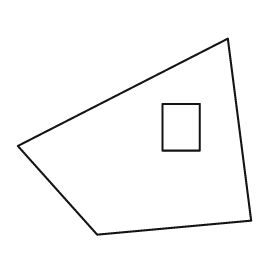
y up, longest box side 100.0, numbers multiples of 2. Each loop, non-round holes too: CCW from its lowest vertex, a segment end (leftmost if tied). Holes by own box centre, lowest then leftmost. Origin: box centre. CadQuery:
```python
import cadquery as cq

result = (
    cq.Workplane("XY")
    .moveTo(-16.0, -42.0)
    .lineTo(50.0, -36.0)
    .lineTo(40.0, 42.0)
    .lineTo(-50.0, -4.0)
    .close()
    .moveTo(12.0, -6.0)
    .lineTo(28.0, -6.0)
    .lineTo(28.0, 14.0)
    .lineTo(12.0, 14.0)
    .close()
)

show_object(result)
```